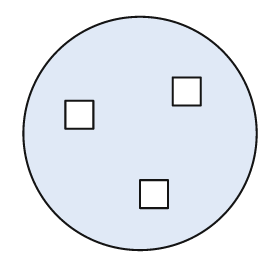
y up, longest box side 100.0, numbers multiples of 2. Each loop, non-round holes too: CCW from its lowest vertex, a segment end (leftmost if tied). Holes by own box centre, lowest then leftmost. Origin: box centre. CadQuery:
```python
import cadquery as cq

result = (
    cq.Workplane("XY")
    .moveTo(0.0, 0.0)
    .circle(50.0)
    .moveTo(0.0, -32.0)
    .lineTo(12.0, -32.0)
    .lineTo(12.0, -20.0)
    .lineTo(0.0, -20.0)
    .close()
    .moveTo(-32.0, 2.0)
    .lineTo(-20.0, 2.0)
    .lineTo(-20.0, 14.0)
    .lineTo(-32.0, 14.0)
    .close()
    .moveTo(14.0, 12.0)
    .lineTo(26.0, 12.0)
    .lineTo(26.0, 24.0)
    .lineTo(14.0, 24.0)
    .close()
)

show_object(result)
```